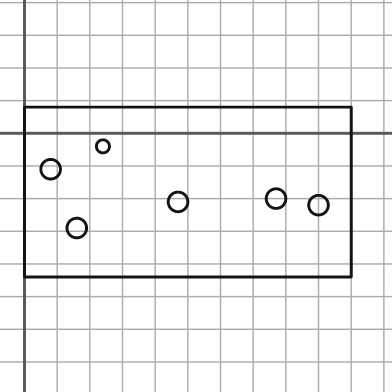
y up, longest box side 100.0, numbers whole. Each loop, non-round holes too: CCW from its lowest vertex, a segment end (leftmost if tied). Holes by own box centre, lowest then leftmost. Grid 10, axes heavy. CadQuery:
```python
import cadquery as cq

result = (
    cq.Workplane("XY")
    .moveTo(0.0, -44.0)
    .lineTo(100.0, -44.0)
    .lineTo(100.0, 8.0)
    .lineTo(0.0, 8.0)
    .close()
    .moveTo(16.0, -29.0)
    .circle(3.0)
    .moveTo(90.0, -22.0)
    .circle(3.0)
    .moveTo(47.0, -21.0)
    .circle(3.0)
    .moveTo(77.0, -20.0)
    .circle(3.0)
    .moveTo(8.0, -11.0)
    .circle(3.0)
    .moveTo(24.0, -4.0)
    .circle(2.0)
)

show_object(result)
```